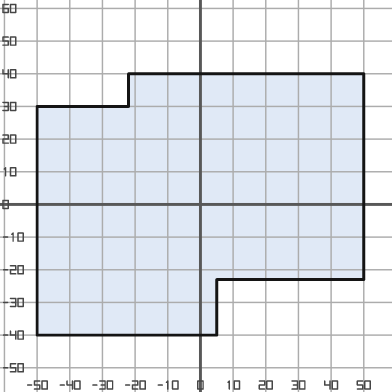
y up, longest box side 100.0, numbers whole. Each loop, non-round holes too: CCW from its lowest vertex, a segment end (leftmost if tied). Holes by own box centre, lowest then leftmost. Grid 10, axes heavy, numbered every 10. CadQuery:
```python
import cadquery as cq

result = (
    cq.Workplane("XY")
    .moveTo(-50.0, -40.0)
    .lineTo(5.0, -40.0)
    .lineTo(5.0, -23.0)
    .lineTo(50.0, -23.0)
    .lineTo(50.0, 40.0)
    .lineTo(-22.0, 40.0)
    .lineTo(-22.0, 30.0)
    .lineTo(-50.0, 30.0)
    .close()
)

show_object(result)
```